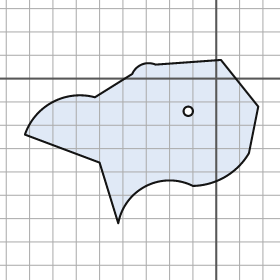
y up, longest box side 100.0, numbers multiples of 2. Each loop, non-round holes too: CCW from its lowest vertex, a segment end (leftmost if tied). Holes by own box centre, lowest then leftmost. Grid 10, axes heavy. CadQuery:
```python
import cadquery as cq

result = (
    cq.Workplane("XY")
    .moveTo(-42.0, -62.0)
    .threePointArc((-30.0, -46.0), (-10.0, -46.0))
    .threePointArc((4.0, -42.0), (14.0, -32.0))
    .lineTo(18.0, -12.0)
    .lineTo(2.0, 8.0)
    .lineTo(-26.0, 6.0)
    .threePointArc((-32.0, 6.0), (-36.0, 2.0))
    .lineTo(-52.0, -8.0)
    .threePointArc((-70.0, -10.0), (-82.0, -24.0))
    .lineTo(-50.0, -36.0)
    .close()
    .moveTo(-12.0, -14.0)
    .circle(2.0)
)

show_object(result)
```